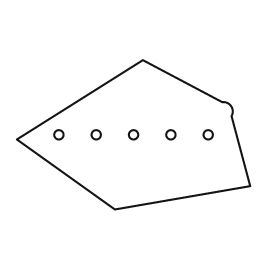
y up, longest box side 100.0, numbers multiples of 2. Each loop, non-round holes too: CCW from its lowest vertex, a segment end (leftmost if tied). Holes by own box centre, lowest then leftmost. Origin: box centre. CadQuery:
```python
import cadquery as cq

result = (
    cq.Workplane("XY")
    .moveTo(-8.0, -32.0)
    .lineTo(50.0, -22.0)
    .lineTo(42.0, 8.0)
    .threePointArc((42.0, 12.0), (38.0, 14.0))
    .lineTo(4.0, 32.0)
    .lineTo(-50.0, -2.0)
    .close()
    .moveTo(-32.0, 0.0)
    .circle(2.0)
    .moveTo(-16.0, 0.0)
    .circle(2.0)
    .moveTo(0.0, 0.0)
    .circle(2.0)
    .moveTo(16.0, 0.0)
    .circle(2.0)
    .moveTo(32.0, 0.0)
    .circle(2.0)
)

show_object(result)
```